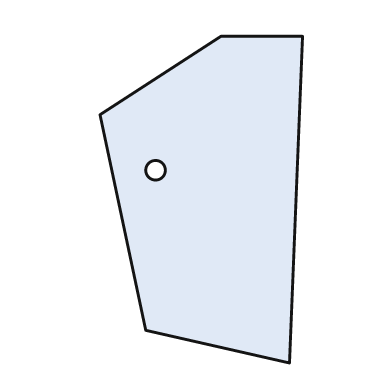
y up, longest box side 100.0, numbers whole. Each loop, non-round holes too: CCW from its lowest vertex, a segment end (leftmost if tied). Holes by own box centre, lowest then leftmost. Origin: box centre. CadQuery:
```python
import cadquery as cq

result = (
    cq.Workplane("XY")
    .moveTo(27.0, -50.0)
    .lineTo(31.0, 50.0)
    .lineTo(6.0, 50.0)
    .lineTo(-31.0, 26.0)
    .lineTo(-17.0, -40.0)
    .close()
    .moveTo(-14.0, 9.0)
    .circle(3.0)
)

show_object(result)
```